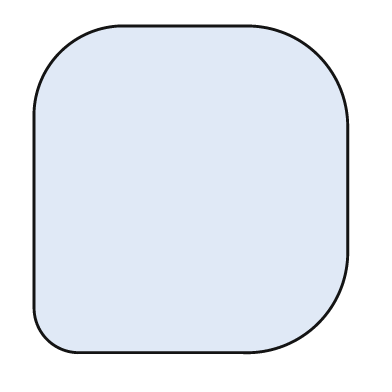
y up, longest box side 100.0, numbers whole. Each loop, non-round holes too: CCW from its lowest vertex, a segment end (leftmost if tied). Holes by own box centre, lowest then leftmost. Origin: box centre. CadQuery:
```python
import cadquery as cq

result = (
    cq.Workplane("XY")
    .moveTo(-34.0, -50.0)
    .lineTo(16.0, -50.0)
    .threePointArc((39.0, -41.0), (48.0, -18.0))
    .lineTo(48.0, 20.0)
    .threePointArc((39.0, 41.0), (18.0, 50.0))
    .lineTo(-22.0, 50.0)
    .threePointArc((-40.0, 42.0), (-48.0, 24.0))
    .lineTo(-48.0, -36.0)
    .threePointArc((-44.0, -46.0), (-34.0, -50.0))
    .close()
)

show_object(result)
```